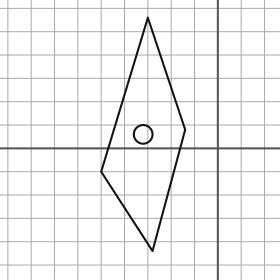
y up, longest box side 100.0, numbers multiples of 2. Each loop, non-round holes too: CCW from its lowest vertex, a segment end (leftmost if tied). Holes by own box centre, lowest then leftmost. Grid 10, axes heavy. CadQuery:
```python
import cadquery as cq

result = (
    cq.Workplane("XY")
    .moveTo(-28.0, -44.0)
    .lineTo(-14.0, 8.0)
    .lineTo(-30.0, 56.0)
    .lineTo(-50.0, -10.0)
    .close()
    .moveTo(-32.0, 6.0)
    .circle(4.0)
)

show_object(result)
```